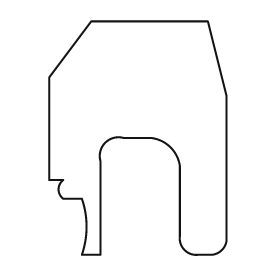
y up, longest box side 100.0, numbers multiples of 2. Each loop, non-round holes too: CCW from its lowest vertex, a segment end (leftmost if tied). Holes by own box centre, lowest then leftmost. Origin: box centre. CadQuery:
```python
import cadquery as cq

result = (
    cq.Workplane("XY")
    .moveTo(-24.0, -50.0)
    .lineTo(-16.0, -50.0)
    .lineTo(-16.0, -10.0)
    .threePointArc((-14.0, -2.0), (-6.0, 0.0))
    .lineTo(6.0, 0.0)
    .threePointArc((14.0, -4.0), (18.0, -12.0))
    .lineTo(18.0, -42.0)
    .threePointArc((20.0, -48.0), (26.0, -50.0))
    .lineTo(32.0, -50.0)
    .threePointArc((36.0, -48.0), (38.0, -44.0))
    .lineTo(38.0, 18.0)
    .lineTo(30.0, 50.0)
    .lineTo(-20.0, 50.0)
    .lineTo(-38.0, 26.0)
    .lineTo(-38.0, -18.0)
    .lineTo(-32.0, -18.0)
    .threePointArc((-34.0, -22.0), (-32.0, -26.0))
    .lineTo(-24.0, -26.0)
    .threePointArc((-22.0, -38.0), (-24.0, -50.0))
    .close()
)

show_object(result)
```